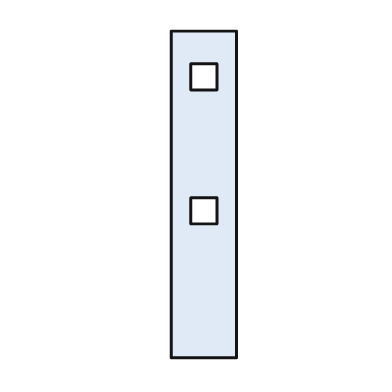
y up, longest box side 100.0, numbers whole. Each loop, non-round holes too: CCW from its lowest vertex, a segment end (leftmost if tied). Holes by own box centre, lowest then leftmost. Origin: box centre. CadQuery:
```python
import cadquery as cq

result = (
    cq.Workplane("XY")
    .moveTo(-10.0, -50.0)
    .lineTo(10.0, -50.0)
    .lineTo(10.0, 50.0)
    .lineTo(-10.0, 50.0)
    .close()
    .moveTo(-4.0, -9.0)
    .lineTo(4.0, -9.0)
    .lineTo(4.0, -1.0)
    .lineTo(-4.0, -1.0)
    .close()
    .moveTo(-4.0, 32.0)
    .lineTo(4.0, 32.0)
    .lineTo(4.0, 40.0)
    .lineTo(-4.0, 40.0)
    .close()
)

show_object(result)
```